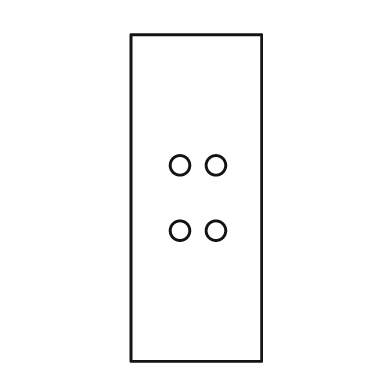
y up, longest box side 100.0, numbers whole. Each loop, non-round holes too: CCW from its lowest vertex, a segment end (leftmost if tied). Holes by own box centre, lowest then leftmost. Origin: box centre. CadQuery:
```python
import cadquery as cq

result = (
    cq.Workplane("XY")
    .moveTo(-20.0, -50.0)
    .lineTo(20.0, -50.0)
    .lineTo(20.0, 50.0)
    .lineTo(-20.0, 50.0)
    .close()
    .moveTo(-5.0, -10.0)
    .circle(3.0)
    .moveTo(6.0, -10.0)
    .circle(3.0)
    .moveTo(-5.0, 10.0)
    .circle(3.0)
    .moveTo(6.0, 10.0)
    .circle(3.0)
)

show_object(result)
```